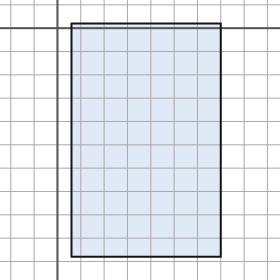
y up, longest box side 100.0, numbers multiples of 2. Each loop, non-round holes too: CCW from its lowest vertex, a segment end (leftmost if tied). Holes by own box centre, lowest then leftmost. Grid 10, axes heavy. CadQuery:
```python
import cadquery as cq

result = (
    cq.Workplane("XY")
    .moveTo(6.0, -98.0)
    .lineTo(70.0, -98.0)
    .lineTo(70.0, 2.0)
    .lineTo(6.0, 2.0)
    .close()
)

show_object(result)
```